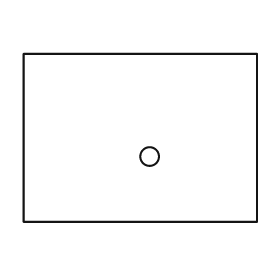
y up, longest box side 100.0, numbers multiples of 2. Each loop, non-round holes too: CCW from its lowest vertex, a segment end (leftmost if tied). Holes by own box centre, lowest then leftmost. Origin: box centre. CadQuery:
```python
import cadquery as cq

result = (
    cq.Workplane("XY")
    .moveTo(-50.0, -36.0)
    .lineTo(50.0, -36.0)
    .lineTo(50.0, 36.0)
    .lineTo(-50.0, 36.0)
    .close()
    .moveTo(4.0, -8.0)
    .circle(4.0)
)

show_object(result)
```